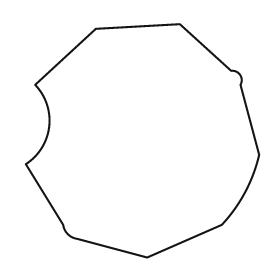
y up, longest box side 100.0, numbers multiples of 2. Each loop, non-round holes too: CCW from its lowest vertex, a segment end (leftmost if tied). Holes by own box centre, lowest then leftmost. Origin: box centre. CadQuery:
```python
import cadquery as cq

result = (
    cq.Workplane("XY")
    .moveTo(2.0, -50.0)
    .lineTo(34.0, -36.0)
    .threePointArc((44.0, -22.0), (50.0, -6.0))
    .lineTo(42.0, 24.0)
    .threePointArc((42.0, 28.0), (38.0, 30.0))
    .lineTo(16.0, 50.0)
    .lineTo(-20.0, 48.0)
    .lineTo(-46.0, 24.0)
    .threePointArc((-40.0, 6.0), (-50.0, -10.0))
    .lineTo(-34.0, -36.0)
    .threePointArc((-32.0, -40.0), (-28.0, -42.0))
    .close()
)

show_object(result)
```